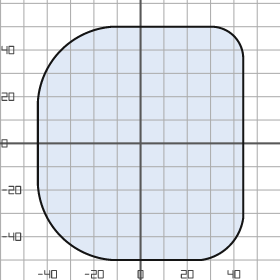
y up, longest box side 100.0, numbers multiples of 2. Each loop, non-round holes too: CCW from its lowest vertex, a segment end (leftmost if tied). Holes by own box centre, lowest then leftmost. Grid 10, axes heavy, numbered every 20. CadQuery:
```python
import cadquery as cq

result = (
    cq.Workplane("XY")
    .moveTo(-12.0, -50.0)
    .lineTo(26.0, -50.0)
    .threePointArc((38.0, -44.0), (44.0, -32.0))
    .lineTo(44.0, 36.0)
    .threePointArc((40.0, 46.0), (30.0, 50.0))
    .lineTo(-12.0, 50.0)
    .threePointArc((-34.0, 40.0), (-44.0, 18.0))
    .lineTo(-44.0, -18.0)
    .threePointArc((-34.0, -40.0), (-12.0, -50.0))
    .close()
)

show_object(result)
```